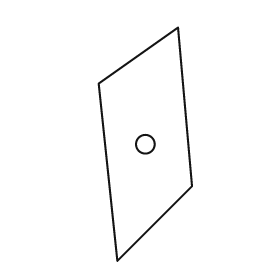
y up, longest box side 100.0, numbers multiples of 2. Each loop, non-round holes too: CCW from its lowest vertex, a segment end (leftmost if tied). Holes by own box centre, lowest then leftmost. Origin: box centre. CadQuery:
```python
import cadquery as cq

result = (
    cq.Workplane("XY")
    .moveTo(-12.0, -50.0)
    .lineTo(20.0, -18.0)
    .lineTo(14.0, 50.0)
    .lineTo(-20.0, 26.0)
    .close()
    .moveTo(0.0, 0.0)
    .circle(4.0)
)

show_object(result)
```